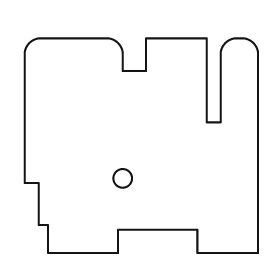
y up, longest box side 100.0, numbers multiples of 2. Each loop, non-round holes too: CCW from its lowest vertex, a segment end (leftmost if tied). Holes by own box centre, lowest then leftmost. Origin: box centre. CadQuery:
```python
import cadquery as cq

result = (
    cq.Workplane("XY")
    .moveTo(-40.0, -46.0)
    .lineTo(-10.0, -46.0)
    .lineTo(-10.0, -36.0)
    .lineTo(24.0, -36.0)
    .lineTo(24.0, -46.0)
    .lineTo(50.0, -46.0)
    .lineTo(50.0, 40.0)
    .threePointArc((48.0, 44.0), (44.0, 46.0))
    .lineTo(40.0, 46.0)
    .threePointArc((36.0, 44.0), (34.0, 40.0))
    .lineTo(34.0, 10.0)
    .lineTo(28.0, 10.0)
    .lineTo(28.0, 46.0)
    .lineTo(2.0, 46.0)
    .lineTo(2.0, 32.0)
    .lineTo(-8.0, 32.0)
    .lineTo(-8.0, 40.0)
    .threePointArc((-10.0, 44.0), (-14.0, 46.0))
    .lineTo(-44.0, 46.0)
    .threePointArc((-48.0, 44.0), (-50.0, 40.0))
    .lineTo(-50.0, -16.0)
    .lineTo(-44.0, -16.0)
    .lineTo(-44.0, -34.0)
    .lineTo(-40.0, -34.0)
    .close()
    .moveTo(-8.0, -14.0)
    .circle(4.0)
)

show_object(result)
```